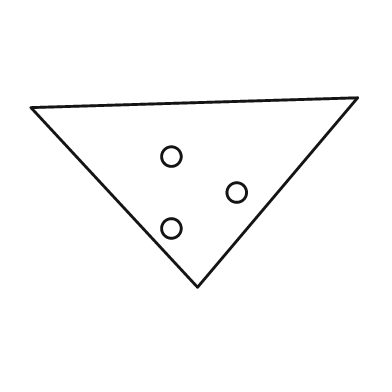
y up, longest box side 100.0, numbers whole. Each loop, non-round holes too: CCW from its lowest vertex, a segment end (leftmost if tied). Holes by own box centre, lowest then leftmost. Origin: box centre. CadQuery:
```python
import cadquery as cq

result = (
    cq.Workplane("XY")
    .moveTo(1.0, -29.0)
    .lineTo(50.0, 29.0)
    .lineTo(-50.0, 26.0)
    .close()
    .moveTo(-7.0, -11.0)
    .circle(3.0)
    .moveTo(13.0, 0.0)
    .circle(3.0)
    .moveTo(-7.0, 11.0)
    .circle(3.0)
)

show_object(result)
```